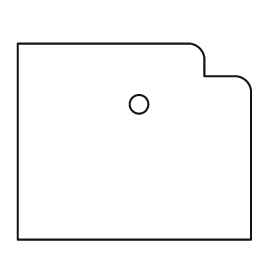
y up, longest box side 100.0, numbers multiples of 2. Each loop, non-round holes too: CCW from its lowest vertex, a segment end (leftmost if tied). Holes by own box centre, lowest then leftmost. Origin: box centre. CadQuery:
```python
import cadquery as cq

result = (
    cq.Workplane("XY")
    .moveTo(-50.0, -42.0)
    .lineTo(50.0, -42.0)
    .lineTo(50.0, 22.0)
    .threePointArc((48.0, 26.0), (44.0, 28.0))
    .lineTo(30.0, 28.0)
    .lineTo(30.0, 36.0)
    .threePointArc((28.0, 40.0), (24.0, 42.0))
    .lineTo(-50.0, 42.0)
    .close()
    .moveTo(2.0, 16.0)
    .circle(4.0)
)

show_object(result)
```